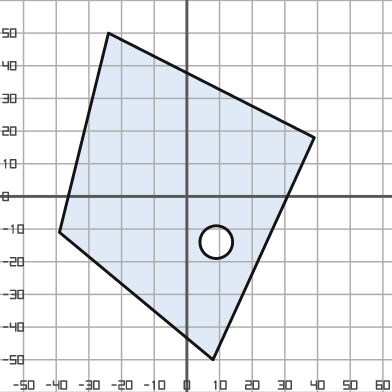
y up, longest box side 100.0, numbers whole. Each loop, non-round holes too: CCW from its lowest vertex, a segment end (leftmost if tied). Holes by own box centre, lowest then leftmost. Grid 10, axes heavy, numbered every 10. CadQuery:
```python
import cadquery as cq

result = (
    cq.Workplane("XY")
    .moveTo(8.0, -50.0)
    .lineTo(39.0, 18.0)
    .lineTo(-24.0, 50.0)
    .lineTo(-39.0, -11.0)
    .close()
    .moveTo(9.0, -14.0)
    .circle(5.0)
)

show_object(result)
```